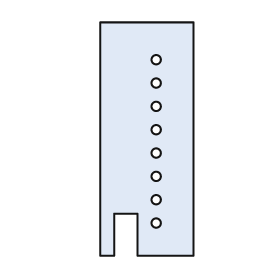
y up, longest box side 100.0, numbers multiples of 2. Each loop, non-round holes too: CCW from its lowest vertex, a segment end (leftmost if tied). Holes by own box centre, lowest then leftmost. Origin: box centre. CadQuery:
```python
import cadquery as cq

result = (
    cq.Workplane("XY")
    .moveTo(-20.0, -50.0)
    .lineTo(-14.0, -50.0)
    .lineTo(-14.0, -32.0)
    .lineTo(-4.0, -32.0)
    .lineTo(-4.0, -50.0)
    .lineTo(20.0, -50.0)
    .lineTo(20.0, 50.0)
    .lineTo(-20.0, 50.0)
    .close()
    .moveTo(4.0, -36.0)
    .circle(2.0)
    .moveTo(4.0, -26.0)
    .circle(2.0)
    .moveTo(4.0, -16.0)
    .circle(2.0)
    .moveTo(4.0, -6.0)
    .circle(2.0)
    .moveTo(4.0, 4.0)
    .circle(2.0)
    .moveTo(4.0, 14.0)
    .circle(2.0)
    .moveTo(4.0, 24.0)
    .circle(2.0)
    .moveTo(4.0, 34.0)
    .circle(2.0)
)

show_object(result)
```